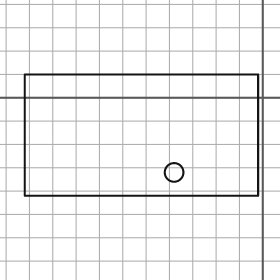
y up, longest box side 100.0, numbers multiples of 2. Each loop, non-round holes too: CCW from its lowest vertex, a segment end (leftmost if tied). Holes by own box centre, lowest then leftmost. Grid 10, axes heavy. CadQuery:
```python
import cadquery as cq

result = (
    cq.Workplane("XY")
    .moveTo(-102.0, -42.0)
    .lineTo(-2.0, -42.0)
    .lineTo(-2.0, 10.0)
    .lineTo(-102.0, 10.0)
    .close()
    .moveTo(-38.0, -32.0)
    .circle(4.0)
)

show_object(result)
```